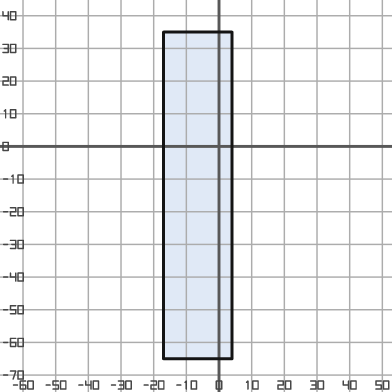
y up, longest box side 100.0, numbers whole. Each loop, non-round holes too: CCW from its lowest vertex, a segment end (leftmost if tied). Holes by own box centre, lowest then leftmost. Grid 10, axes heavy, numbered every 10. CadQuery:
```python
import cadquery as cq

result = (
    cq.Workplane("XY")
    .moveTo(-17.0, -65.0)
    .lineTo(4.0, -65.0)
    .lineTo(4.0, 35.0)
    .lineTo(-17.0, 35.0)
    .close()
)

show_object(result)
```